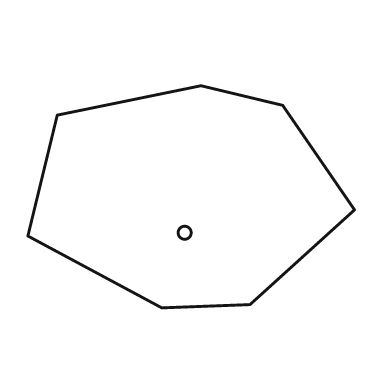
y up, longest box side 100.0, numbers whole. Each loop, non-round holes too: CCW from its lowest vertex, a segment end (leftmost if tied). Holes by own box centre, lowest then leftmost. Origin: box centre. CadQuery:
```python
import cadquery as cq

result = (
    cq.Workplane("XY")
    .moveTo(-9.0, -34.0)
    .lineTo(18.0, -33.0)
    .lineTo(50.0, -4.0)
    .lineTo(28.0, 28.0)
    .lineTo(3.0, 34.0)
    .lineTo(-41.0, 25.0)
    .lineTo(-50.0, -12.0)
    .close()
    .moveTo(-2.0, -11.0)
    .circle(2.0)
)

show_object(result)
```